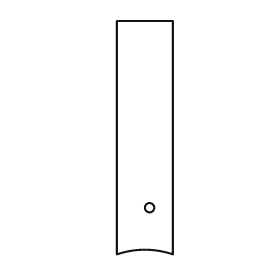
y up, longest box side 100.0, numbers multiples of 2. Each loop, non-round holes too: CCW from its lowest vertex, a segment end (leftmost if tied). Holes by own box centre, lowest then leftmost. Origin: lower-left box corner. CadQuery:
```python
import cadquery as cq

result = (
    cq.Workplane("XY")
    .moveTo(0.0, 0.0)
    .threePointArc((12.0, 2.0), (24.0, 0.0))
    .lineTo(24.0, 100.0)
    .lineTo(0.0, 100.0)
    .close()
    .moveTo(14.0, 20.0)
    .circle(2.0)
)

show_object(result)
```